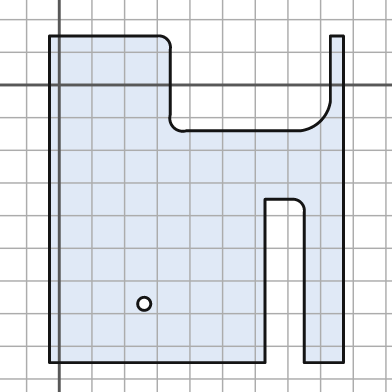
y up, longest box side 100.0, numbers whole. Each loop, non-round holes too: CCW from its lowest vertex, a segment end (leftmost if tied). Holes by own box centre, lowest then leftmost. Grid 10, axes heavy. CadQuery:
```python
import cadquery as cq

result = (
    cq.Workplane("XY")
    .moveTo(-3.0, -85.0)
    .lineTo(63.0, -85.0)
    .lineTo(63.0, -35.0)
    .lineTo(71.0, -35.0)
    .threePointArc((74.0, -36.0), (75.0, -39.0))
    .lineTo(75.0, -85.0)
    .lineTo(87.0, -85.0)
    .lineTo(87.0, 15.0)
    .lineTo(83.0, 15.0)
    .lineTo(83.0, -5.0)
    .threePointArc((80.0, -11.0), (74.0, -14.0))
    .lineTo(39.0, -14.0)
    .threePointArc((35.0, -13.0), (34.0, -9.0))
    .lineTo(34.0, 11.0)
    .threePointArc((33.0, 14.0), (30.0, 15.0))
    .lineTo(-3.0, 15.0)
    .close()
    .moveTo(26.0, -67.0)
    .circle(2.0)
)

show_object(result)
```